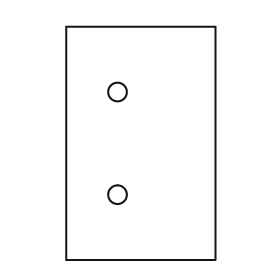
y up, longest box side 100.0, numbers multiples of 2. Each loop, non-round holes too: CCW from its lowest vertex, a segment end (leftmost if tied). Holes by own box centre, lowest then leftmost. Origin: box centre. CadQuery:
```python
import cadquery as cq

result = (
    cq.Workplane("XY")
    .moveTo(-32.0, -50.0)
    .lineTo(32.0, -50.0)
    .lineTo(32.0, 50.0)
    .lineTo(-32.0, 50.0)
    .close()
    .moveTo(-10.0, -22.0)
    .circle(4.0)
    .moveTo(-10.0, 22.0)
    .circle(4.0)
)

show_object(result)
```